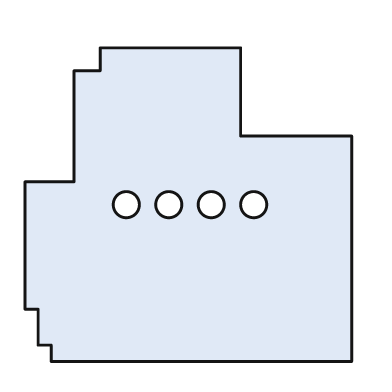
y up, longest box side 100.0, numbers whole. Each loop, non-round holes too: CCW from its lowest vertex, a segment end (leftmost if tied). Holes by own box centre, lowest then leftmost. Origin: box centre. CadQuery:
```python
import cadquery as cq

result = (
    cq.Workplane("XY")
    .moveTo(-42.0, -48.0)
    .lineTo(50.0, -48.0)
    .lineTo(50.0, 21.0)
    .lineTo(16.0, 21.0)
    .lineTo(16.0, 48.0)
    .lineTo(-27.0, 48.0)
    .lineTo(-27.0, 41.0)
    .lineTo(-35.0, 41.0)
    .lineTo(-35.0, 7.0)
    .lineTo(-50.0, 7.0)
    .lineTo(-50.0, -32.0)
    .lineTo(-46.0, -32.0)
    .lineTo(-46.0, -43.0)
    .lineTo(-42.0, -43.0)
    .close()
    .moveTo(-19.0, 0.0)
    .circle(4.0)
    .moveTo(-6.0, 0.0)
    .circle(4.0)
    .moveTo(7.0, 0.0)
    .circle(4.0)
    .moveTo(20.0, 0.0)
    .circle(4.0)
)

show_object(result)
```